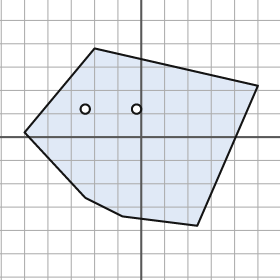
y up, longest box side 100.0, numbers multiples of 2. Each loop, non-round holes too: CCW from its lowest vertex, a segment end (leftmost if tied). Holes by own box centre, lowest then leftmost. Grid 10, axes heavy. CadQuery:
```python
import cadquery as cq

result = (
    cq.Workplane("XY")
    .moveTo(24.0, -38.0)
    .lineTo(50.0, 22.0)
    .lineTo(-20.0, 38.0)
    .lineTo(-50.0, 2.0)
    .lineTo(-24.0, -26.0)
    .lineTo(-8.0, -34.0)
    .close()
    .moveTo(-24.0, 12.0)
    .circle(2.0)
    .moveTo(-2.0, 12.0)
    .circle(2.0)
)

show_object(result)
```